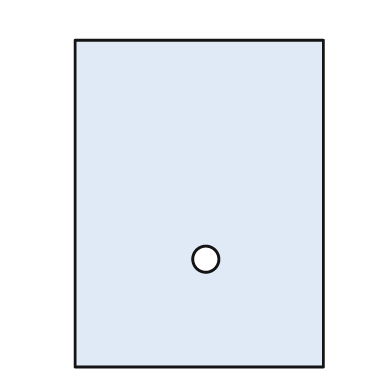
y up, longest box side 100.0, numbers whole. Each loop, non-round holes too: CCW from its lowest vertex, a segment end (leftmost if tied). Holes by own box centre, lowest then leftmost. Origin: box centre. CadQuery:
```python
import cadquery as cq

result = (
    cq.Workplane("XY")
    .moveTo(-38.0, -50.0)
    .lineTo(38.0, -50.0)
    .lineTo(38.0, 50.0)
    .lineTo(-38.0, 50.0)
    .close()
    .moveTo(2.0, -17.0)
    .circle(4.0)
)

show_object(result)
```